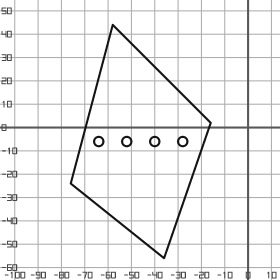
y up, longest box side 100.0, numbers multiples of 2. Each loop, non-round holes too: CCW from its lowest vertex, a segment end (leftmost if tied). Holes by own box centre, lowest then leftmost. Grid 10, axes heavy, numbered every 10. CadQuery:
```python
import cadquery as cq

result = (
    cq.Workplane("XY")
    .moveTo(-36.0, -56.0)
    .lineTo(-16.0, 2.0)
    .lineTo(-58.0, 44.0)
    .lineTo(-76.0, -24.0)
    .close()
    .moveTo(-64.0, -6.0)
    .circle(2.0)
    .moveTo(-52.0, -6.0)
    .circle(2.0)
    .moveTo(-40.0, -6.0)
    .circle(2.0)
    .moveTo(-28.0, -6.0)
    .circle(2.0)
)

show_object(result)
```